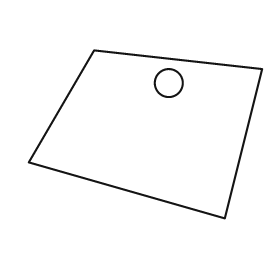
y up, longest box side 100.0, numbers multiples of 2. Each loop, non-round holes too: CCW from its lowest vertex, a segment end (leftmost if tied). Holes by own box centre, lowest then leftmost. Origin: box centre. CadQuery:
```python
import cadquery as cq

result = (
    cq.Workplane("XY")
    .moveTo(34.0, -36.0)
    .lineTo(50.0, 28.0)
    .lineTo(-22.0, 36.0)
    .lineTo(-50.0, -12.0)
    .close()
    .moveTo(10.0, 22.0)
    .circle(6.0)
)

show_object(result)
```